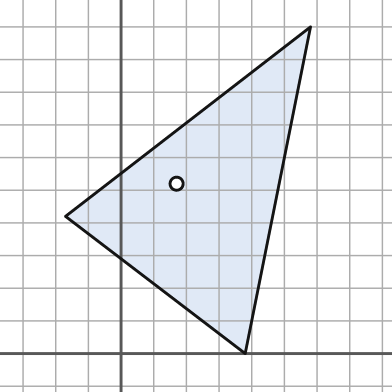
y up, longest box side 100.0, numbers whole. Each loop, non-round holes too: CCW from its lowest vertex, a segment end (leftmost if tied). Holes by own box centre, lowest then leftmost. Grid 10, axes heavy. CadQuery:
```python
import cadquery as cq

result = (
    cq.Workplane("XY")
    .moveTo(38.0, 0.0)
    .lineTo(58.0, 100.0)
    .lineTo(-17.0, 42.0)
    .close()
    .moveTo(17.0, 52.0)
    .circle(2.0)
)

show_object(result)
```